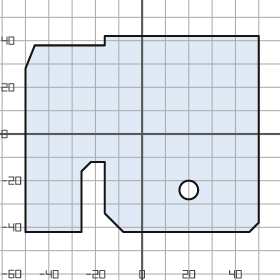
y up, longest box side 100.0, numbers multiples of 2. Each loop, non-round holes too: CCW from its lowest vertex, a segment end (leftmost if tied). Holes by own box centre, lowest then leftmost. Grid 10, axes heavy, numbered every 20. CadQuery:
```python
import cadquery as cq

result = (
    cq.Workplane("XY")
    .moveTo(-50.0, -42.0)
    .lineTo(-26.0, -42.0)
    .lineTo(-26.0, -16.0)
    .lineTo(-22.0, -12.0)
    .lineTo(-16.0, -12.0)
    .lineTo(-16.0, -34.0)
    .lineTo(-8.0, -42.0)
    .lineTo(46.0, -42.0)
    .lineTo(50.0, -38.0)
    .lineTo(50.0, 42.0)
    .lineTo(-16.0, 42.0)
    .lineTo(-16.0, 38.0)
    .lineTo(-46.0, 38.0)
    .lineTo(-50.0, 28.0)
    .close()
    .moveTo(20.0, -24.0)
    .circle(4.0)
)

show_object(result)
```